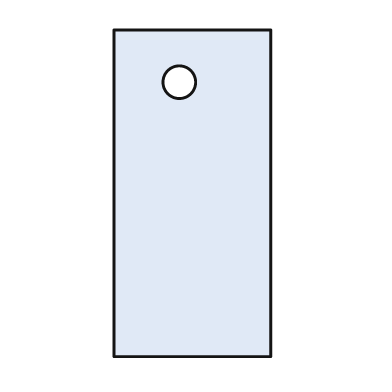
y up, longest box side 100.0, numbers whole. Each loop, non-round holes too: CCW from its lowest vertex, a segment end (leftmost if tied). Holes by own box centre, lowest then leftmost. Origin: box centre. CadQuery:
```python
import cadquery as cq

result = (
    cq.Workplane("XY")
    .moveTo(-24.0, -50.0)
    .lineTo(24.0, -50.0)
    .lineTo(24.0, 50.0)
    .lineTo(-24.0, 50.0)
    .close()
    .moveTo(-4.0, 34.0)
    .circle(5.0)
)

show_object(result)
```